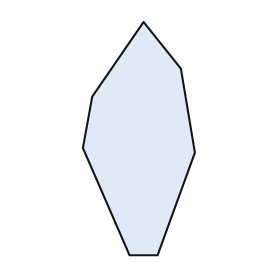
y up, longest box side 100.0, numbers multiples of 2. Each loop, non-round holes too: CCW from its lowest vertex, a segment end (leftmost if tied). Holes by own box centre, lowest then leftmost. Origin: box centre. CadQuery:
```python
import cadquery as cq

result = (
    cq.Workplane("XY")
    .moveTo(-4.0, -50.0)
    .lineTo(8.0, -50.0)
    .lineTo(24.0, -6.0)
    .lineTo(18.0, 30.0)
    .lineTo(2.0, 50.0)
    .lineTo(-20.0, 18.0)
    .lineTo(-24.0, -4.0)
    .close()
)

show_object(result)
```